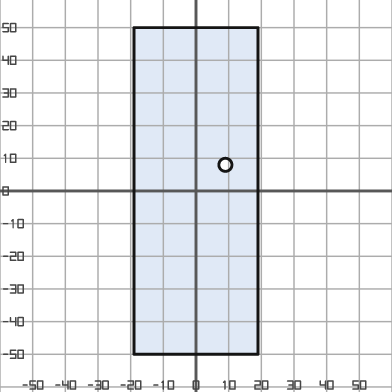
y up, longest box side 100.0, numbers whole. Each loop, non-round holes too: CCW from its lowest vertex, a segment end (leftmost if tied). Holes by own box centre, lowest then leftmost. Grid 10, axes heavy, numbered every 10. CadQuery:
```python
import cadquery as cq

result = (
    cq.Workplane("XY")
    .moveTo(-19.0, -50.0)
    .lineTo(19.0, -50.0)
    .lineTo(19.0, 50.0)
    .lineTo(-19.0, 50.0)
    .close()
    .moveTo(9.0, 8.0)
    .circle(2.0)
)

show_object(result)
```